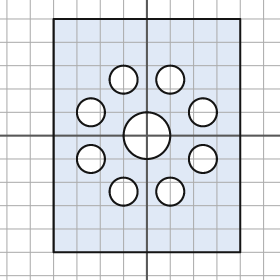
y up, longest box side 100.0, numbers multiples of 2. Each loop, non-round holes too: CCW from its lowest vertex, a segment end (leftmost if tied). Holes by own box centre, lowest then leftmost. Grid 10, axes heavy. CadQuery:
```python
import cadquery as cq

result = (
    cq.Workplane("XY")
    .moveTo(-40.0, -50.0)
    .lineTo(40.0, -50.0)
    .lineTo(40.0, 50.0)
    .lineTo(-40.0, 50.0)
    .close()
    .moveTo(-10.0, -24.0)
    .circle(6.0)
    .moveTo(10.0, -24.0)
    .circle(6.0)
    .moveTo(-24.0, -10.0)
    .circle(6.0)
    .moveTo(24.0, -10.0)
    .circle(6.0)
    .moveTo(0.0, 0.0)
    .circle(10.0)
    .moveTo(-24.0, 10.0)
    .circle(6.0)
    .moveTo(24.0, 10.0)
    .circle(6.0)
    .moveTo(-10.0, 24.0)
    .circle(6.0)
    .moveTo(10.0, 24.0)
    .circle(6.0)
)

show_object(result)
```